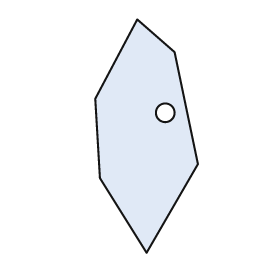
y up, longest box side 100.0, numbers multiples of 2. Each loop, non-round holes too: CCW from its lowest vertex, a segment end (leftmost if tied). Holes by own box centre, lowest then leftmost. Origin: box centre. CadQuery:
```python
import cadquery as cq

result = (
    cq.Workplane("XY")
    .moveTo(0.0, -50.0)
    .lineTo(22.0, -12.0)
    .lineTo(12.0, 36.0)
    .lineTo(-4.0, 50.0)
    .lineTo(-22.0, 16.0)
    .lineTo(-20.0, -18.0)
    .close()
    .moveTo(8.0, 10.0)
    .circle(4.0)
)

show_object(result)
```